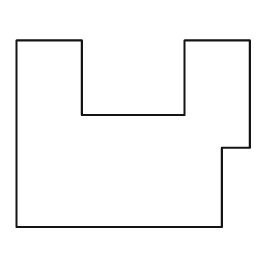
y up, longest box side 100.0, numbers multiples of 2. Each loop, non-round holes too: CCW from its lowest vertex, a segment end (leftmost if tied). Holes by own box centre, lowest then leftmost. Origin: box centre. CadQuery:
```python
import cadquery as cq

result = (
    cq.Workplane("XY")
    .moveTo(-50.0, -40.0)
    .lineTo(38.0, -40.0)
    .lineTo(38.0, -6.0)
    .lineTo(50.0, -6.0)
    .lineTo(50.0, 40.0)
    .lineTo(22.0, 40.0)
    .lineTo(22.0, 8.0)
    .lineTo(-22.0, 8.0)
    .lineTo(-22.0, 40.0)
    .lineTo(-50.0, 40.0)
    .close()
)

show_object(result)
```